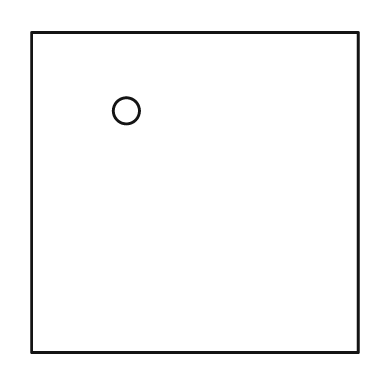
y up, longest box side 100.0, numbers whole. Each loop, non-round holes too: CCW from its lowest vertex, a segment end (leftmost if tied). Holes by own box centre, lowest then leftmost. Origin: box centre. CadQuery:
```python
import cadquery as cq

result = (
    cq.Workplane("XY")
    .moveTo(-50.0, -49.0)
    .lineTo(50.0, -49.0)
    .lineTo(50.0, 49.0)
    .lineTo(-50.0, 49.0)
    .close()
    .moveTo(-21.0, 25.0)
    .circle(4.0)
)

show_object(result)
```